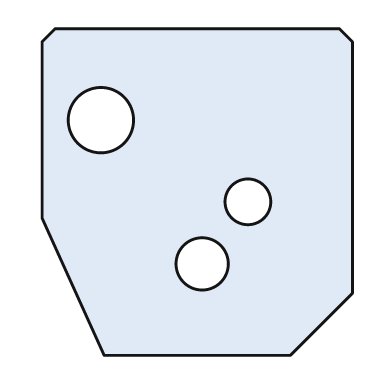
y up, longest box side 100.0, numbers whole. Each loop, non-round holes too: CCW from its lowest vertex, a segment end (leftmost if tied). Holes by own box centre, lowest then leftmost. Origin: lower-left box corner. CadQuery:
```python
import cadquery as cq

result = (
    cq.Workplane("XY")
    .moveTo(19.0, 0.0)
    .lineTo(76.0, 0.0)
    .lineTo(95.0, 19.0)
    .lineTo(95.0, 96.0)
    .lineTo(91.0, 100.0)
    .lineTo(4.0, 100.0)
    .lineTo(0.0, 96.0)
    .lineTo(0.0, 42.0)
    .close()
    .moveTo(49.0, 28.0)
    .circle(8.0)
    .moveTo(63.0, 47.0)
    .circle(7.0)
    .moveTo(18.0, 72.0)
    .circle(10.0)
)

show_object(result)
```